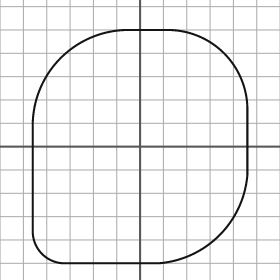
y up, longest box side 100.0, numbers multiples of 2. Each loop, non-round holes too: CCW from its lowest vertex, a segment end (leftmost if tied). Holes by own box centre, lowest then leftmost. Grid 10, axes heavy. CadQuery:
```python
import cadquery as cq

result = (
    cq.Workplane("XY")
    .moveTo(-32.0, -50.0)
    .lineTo(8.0, -50.0)
    .threePointArc((34.0, -38.0), (46.0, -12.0))
    .lineTo(46.0, 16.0)
    .threePointArc((36.0, 40.0), (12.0, 50.0))
    .lineTo(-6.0, 50.0)
    .threePointArc((-34.0, 38.0), (-46.0, 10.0))
    .lineTo(-46.0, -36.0)
    .threePointArc((-42.0, -46.0), (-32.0, -50.0))
    .close()
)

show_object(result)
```